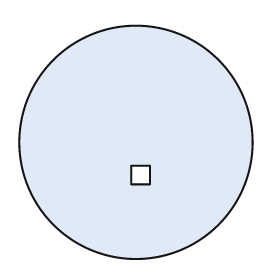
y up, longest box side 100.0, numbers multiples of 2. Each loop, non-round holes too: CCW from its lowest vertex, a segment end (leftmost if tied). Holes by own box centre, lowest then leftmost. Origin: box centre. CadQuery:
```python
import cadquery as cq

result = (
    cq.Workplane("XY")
    .moveTo(0.0, 0.0)
    .circle(50.0)
    .moveTo(-2.0, -18.0)
    .lineTo(6.0, -18.0)
    .lineTo(6.0, -10.0)
    .lineTo(-2.0, -10.0)
    .close()
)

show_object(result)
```